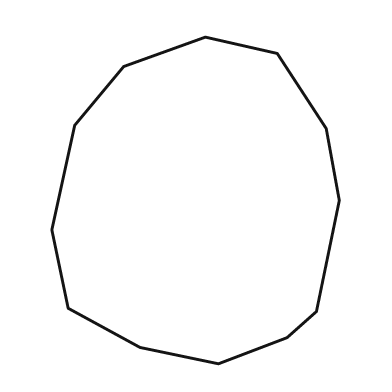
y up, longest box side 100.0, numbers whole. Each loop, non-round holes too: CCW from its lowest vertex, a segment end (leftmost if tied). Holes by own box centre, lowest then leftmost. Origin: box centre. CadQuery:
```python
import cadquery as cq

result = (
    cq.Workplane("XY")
    .moveTo(7.0, -50.0)
    .lineTo(28.0, -42.0)
    .lineTo(37.0, -34.0)
    .lineTo(44.0, 0.0)
    .lineTo(40.0, 22.0)
    .lineTo(25.0, 45.0)
    .lineTo(3.0, 50.0)
    .lineTo(-22.0, 41.0)
    .lineTo(-37.0, 23.0)
    .lineTo(-44.0, -9.0)
    .lineTo(-39.0, -33.0)
    .lineTo(-17.0, -45.0)
    .close()
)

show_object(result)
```